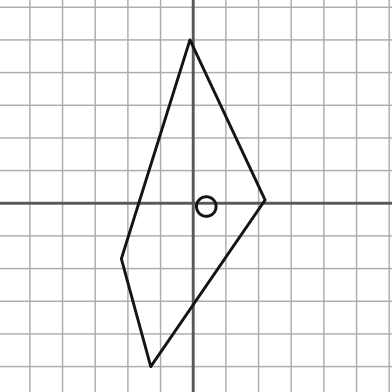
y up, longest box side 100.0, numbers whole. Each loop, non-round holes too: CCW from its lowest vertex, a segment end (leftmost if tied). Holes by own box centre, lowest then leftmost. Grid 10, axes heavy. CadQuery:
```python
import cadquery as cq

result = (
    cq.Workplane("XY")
    .moveTo(-13.0, -50.0)
    .lineTo(22.0, 1.0)
    .lineTo(-1.0, 50.0)
    .lineTo(-22.0, -17.0)
    .close()
    .moveTo(4.0, -1.0)
    .circle(3.0)
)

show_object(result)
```